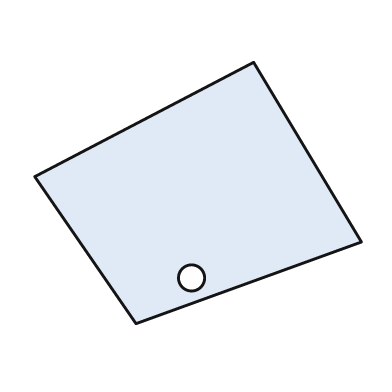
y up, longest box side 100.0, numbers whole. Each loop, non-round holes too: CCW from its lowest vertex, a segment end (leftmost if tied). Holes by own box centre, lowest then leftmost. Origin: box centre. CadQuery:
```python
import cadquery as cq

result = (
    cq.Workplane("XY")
    .moveTo(-19.0, -40.0)
    .lineTo(50.0, -15.0)
    .lineTo(17.0, 40.0)
    .lineTo(-50.0, 5.0)
    .close()
    .moveTo(-2.0, -26.0)
    .circle(4.0)
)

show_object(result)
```